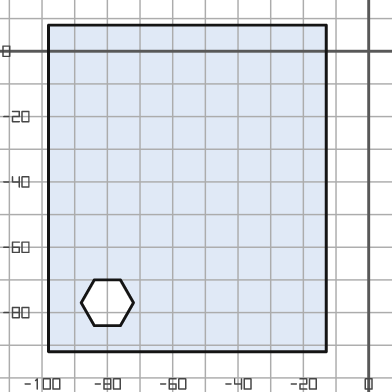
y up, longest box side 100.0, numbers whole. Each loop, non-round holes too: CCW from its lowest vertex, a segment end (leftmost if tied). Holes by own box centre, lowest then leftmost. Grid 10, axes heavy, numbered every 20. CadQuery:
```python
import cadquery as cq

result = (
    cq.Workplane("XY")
    .moveTo(-98.0, -92.0)
    .lineTo(-13.0, -92.0)
    .lineTo(-13.0, 8.0)
    .lineTo(-98.0, 8.0)
    .close()
    .moveTo(-84.0, -84.0)
    .lineTo(-76.0, -84.0)
    .lineTo(-72.0, -77.0)
    .lineTo(-76.0, -70.0)
    .lineTo(-84.0, -70.0)
    .lineTo(-88.0, -77.0)
    .close()
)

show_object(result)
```